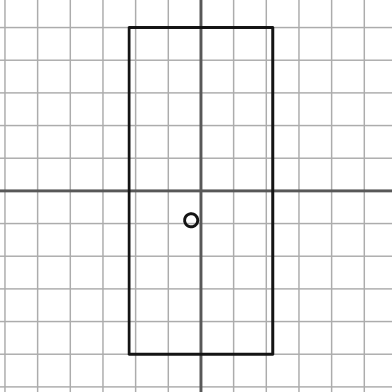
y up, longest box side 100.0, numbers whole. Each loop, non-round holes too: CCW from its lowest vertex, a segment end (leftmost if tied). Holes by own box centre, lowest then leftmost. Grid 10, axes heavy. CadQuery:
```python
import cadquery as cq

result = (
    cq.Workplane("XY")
    .moveTo(-22.0, -50.0)
    .lineTo(22.0, -50.0)
    .lineTo(22.0, 50.0)
    .lineTo(-22.0, 50.0)
    .close()
    .moveTo(-3.0, -9.0)
    .circle(2.0)
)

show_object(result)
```